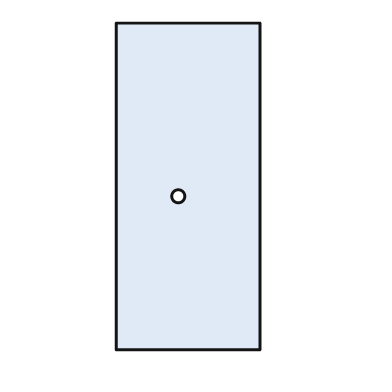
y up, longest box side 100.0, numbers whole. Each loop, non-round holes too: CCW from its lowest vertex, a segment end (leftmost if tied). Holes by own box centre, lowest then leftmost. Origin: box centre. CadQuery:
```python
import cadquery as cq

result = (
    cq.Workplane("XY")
    .moveTo(-22.0, -50.0)
    .lineTo(22.0, -50.0)
    .lineTo(22.0, 50.0)
    .lineTo(-22.0, 50.0)
    .close()
    .moveTo(-3.0, -3.0)
    .circle(2.0)
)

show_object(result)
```